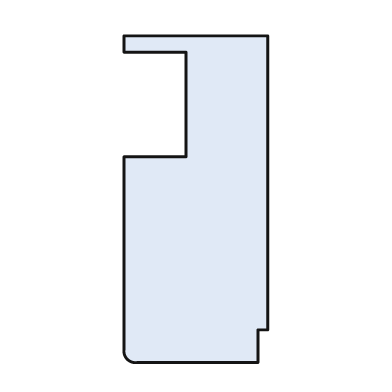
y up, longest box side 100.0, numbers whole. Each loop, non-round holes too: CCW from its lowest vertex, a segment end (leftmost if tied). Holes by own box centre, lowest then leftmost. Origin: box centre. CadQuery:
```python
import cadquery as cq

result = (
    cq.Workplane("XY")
    .moveTo(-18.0, -50.0)
    .lineTo(19.0, -50.0)
    .lineTo(19.0, -40.0)
    .lineTo(22.0, -40.0)
    .lineTo(22.0, 50.0)
    .lineTo(-22.0, 50.0)
    .lineTo(-22.0, 45.0)
    .lineTo(-3.0, 45.0)
    .lineTo(-3.0, 13.0)
    .lineTo(-22.0, 13.0)
    .lineTo(-22.0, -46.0)
    .threePointArc((-21.0, -49.0), (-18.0, -50.0))
    .close()
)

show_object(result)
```